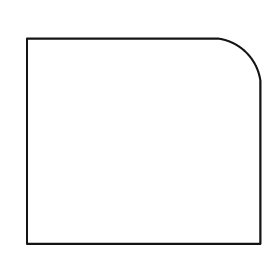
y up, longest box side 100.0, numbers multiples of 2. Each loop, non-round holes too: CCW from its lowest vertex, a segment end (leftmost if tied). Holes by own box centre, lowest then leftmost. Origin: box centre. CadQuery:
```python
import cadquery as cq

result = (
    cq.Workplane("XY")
    .moveTo(-50.0, -44.0)
    .lineTo(50.0, -44.0)
    .lineTo(50.0, 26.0)
    .threePointArc((44.0, 38.0), (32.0, 44.0))
    .lineTo(-50.0, 44.0)
    .close()
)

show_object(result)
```